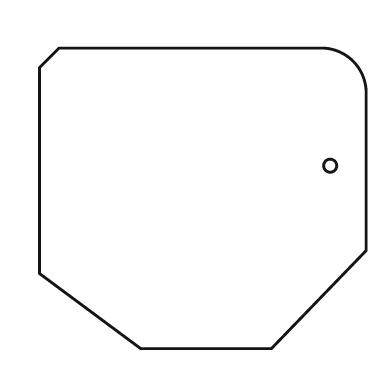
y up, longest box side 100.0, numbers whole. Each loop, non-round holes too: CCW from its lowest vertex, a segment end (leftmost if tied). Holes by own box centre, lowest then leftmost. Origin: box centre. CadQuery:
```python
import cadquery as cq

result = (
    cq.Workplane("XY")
    .moveTo(-19.0, -46.0)
    .lineTo(21.0, -46.0)
    .lineTo(50.0, -16.0)
    .lineTo(50.0, 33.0)
    .threePointArc((46.0, 42.0), (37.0, 46.0))
    .lineTo(-44.0, 46.0)
    .lineTo(-50.0, 40.0)
    .lineTo(-50.0, -23.0)
    .close()
    .moveTo(39.0, 10.0)
    .circle(2.0)
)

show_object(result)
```